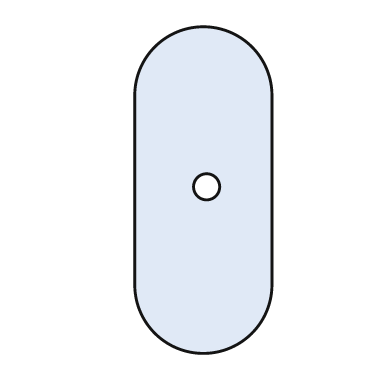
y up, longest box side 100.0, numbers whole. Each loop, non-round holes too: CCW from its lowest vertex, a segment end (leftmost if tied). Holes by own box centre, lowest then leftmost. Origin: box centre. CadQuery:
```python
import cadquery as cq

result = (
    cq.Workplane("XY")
    .moveTo(-21.0, -29.0)
    .threePointArc((0.0, -50.0), (21.0, -29.0))
    .lineTo(21.0, 29.0)
    .threePointArc((0.0, 50.0), (-21.0, 29.0))
    .close()
    .moveTo(1.0, 1.0)
    .circle(4.0)
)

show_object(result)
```